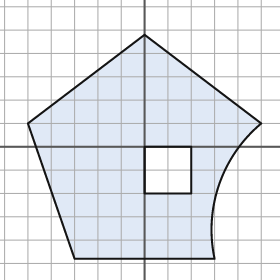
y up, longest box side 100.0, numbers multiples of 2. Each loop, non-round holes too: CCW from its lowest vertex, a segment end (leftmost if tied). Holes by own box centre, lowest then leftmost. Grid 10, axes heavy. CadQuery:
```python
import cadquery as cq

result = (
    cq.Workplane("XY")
    .moveTo(-30.0, -48.0)
    .lineTo(30.0, -48.0)
    .threePointArc((32.0, -16.0), (50.0, 10.0))
    .lineTo(0.0, 48.0)
    .lineTo(-50.0, 10.0)
    .close()
    .moveTo(0.0, -20.0)
    .lineTo(20.0, -20.0)
    .lineTo(20.0, 0.0)
    .lineTo(0.0, 0.0)
    .close()
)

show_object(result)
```